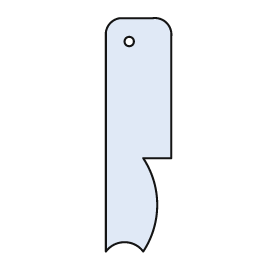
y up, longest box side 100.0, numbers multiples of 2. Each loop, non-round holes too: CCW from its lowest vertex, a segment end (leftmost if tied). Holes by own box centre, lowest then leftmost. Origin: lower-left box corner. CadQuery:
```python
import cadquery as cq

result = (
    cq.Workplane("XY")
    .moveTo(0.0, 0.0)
    .threePointArc((8.0, 4.0), (16.0, 0.0))
    .threePointArc((22.0, 20.0), (16.0, 40.0))
    .lineTo(28.0, 40.0)
    .lineTo(28.0, 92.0)
    .threePointArc((26.0, 98.0), (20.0, 100.0))
    .lineTo(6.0, 100.0)
    .threePointArc((2.0, 98.0), (0.0, 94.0))
    .close()
    .moveTo(10.0, 90.0)
    .circle(2.0)
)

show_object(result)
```